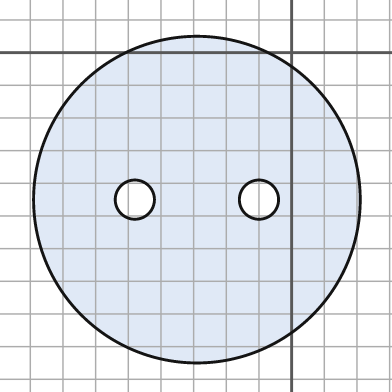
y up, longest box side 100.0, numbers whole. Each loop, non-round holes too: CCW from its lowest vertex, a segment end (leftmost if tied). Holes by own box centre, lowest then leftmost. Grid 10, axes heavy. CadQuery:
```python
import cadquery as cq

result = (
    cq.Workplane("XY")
    .moveTo(-29.0, -45.0)
    .circle(50.0)
    .moveTo(-48.0, -45.0)
    .circle(6.0)
    .moveTo(-10.0, -45.0)
    .circle(6.0)
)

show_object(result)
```